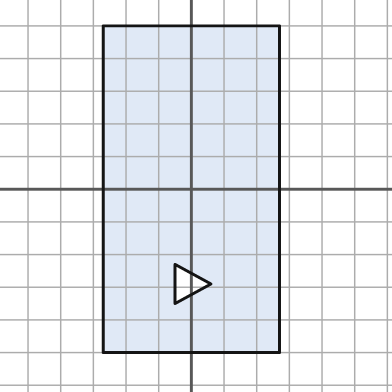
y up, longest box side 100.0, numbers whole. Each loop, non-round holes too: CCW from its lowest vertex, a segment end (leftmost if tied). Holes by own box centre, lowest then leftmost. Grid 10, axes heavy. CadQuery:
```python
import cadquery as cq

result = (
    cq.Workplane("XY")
    .moveTo(-27.0, -50.0)
    .lineTo(27.0, -50.0)
    .lineTo(27.0, 50.0)
    .lineTo(-27.0, 50.0)
    .close()
    .moveTo(-5.0, -35.0)
    .lineTo(6.0, -29.0)
    .lineTo(-5.0, -23.0)
    .close()
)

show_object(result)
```